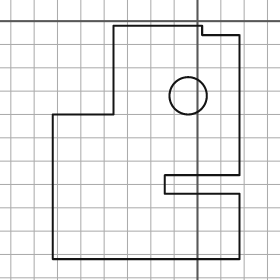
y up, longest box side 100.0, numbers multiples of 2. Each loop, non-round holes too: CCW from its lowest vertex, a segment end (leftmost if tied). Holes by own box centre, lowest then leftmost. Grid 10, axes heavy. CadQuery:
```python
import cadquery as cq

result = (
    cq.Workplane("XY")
    .moveTo(-62.0, -102.0)
    .lineTo(18.0, -102.0)
    .lineTo(18.0, -74.0)
    .lineTo(-14.0, -74.0)
    .lineTo(-14.0, -66.0)
    .lineTo(18.0, -66.0)
    .lineTo(18.0, -6.0)
    .lineTo(2.0, -6.0)
    .lineTo(2.0, -2.0)
    .lineTo(-36.0, -2.0)
    .lineTo(-36.0, -40.0)
    .lineTo(-62.0, -40.0)
    .close()
    .moveTo(-4.0, -32.0)
    .circle(8.0)
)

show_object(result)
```